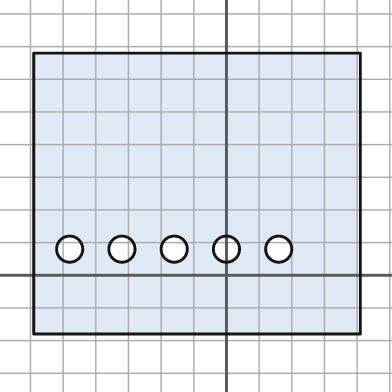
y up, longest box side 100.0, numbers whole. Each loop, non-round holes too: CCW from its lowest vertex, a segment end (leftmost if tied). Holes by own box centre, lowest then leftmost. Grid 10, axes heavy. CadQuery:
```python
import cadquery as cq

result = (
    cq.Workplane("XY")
    .moveTo(-59.0, -18.0)
    .lineTo(41.0, -18.0)
    .lineTo(41.0, 68.0)
    .lineTo(-59.0, 68.0)
    .close()
    .moveTo(-48.0, 8.0)
    .circle(4.0)
    .moveTo(-32.0, 8.0)
    .circle(4.0)
    .moveTo(-16.0, 8.0)
    .circle(4.0)
    .moveTo(0.0, 8.0)
    .circle(4.0)
    .moveTo(16.0, 8.0)
    .circle(4.0)
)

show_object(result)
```